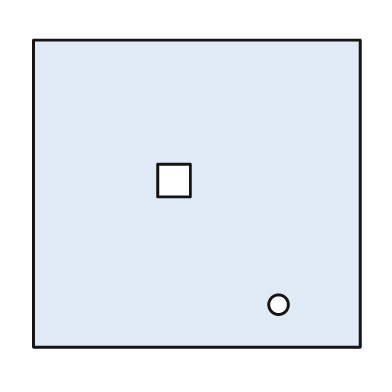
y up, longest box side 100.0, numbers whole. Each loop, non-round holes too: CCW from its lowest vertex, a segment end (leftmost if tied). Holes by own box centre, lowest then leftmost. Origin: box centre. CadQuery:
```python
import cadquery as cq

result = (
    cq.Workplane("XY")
    .moveTo(-50.0, -47.0)
    .lineTo(50.0, -47.0)
    .lineTo(50.0, 47.0)
    .lineTo(-50.0, 47.0)
    .close()
    .moveTo(25.0, -34.0)
    .circle(3.0)
    .moveTo(-12.0, -1.0)
    .lineTo(-2.0, -1.0)
    .lineTo(-2.0, 9.0)
    .lineTo(-12.0, 9.0)
    .close()
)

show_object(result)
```